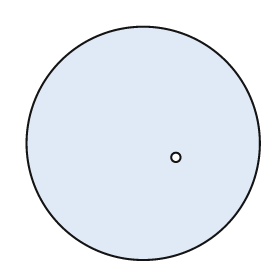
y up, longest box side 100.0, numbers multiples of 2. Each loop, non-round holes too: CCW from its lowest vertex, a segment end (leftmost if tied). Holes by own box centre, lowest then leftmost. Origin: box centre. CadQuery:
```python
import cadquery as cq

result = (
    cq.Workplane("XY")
    .moveTo(0.0, 0.0)
    .circle(50.0)
    .moveTo(14.0, -6.0)
    .circle(2.0)
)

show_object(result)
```